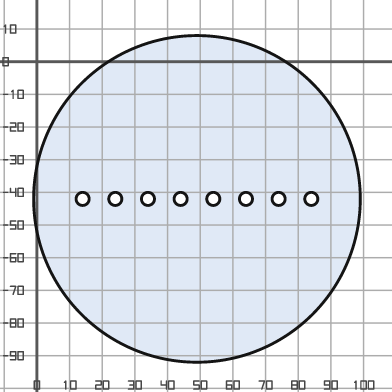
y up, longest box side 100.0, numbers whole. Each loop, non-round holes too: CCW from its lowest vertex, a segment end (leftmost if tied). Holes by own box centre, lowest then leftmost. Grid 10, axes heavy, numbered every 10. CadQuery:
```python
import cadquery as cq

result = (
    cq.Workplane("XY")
    .moveTo(49.0, -42.0)
    .circle(50.0)
    .moveTo(14.0, -42.0)
    .circle(2.0)
    .moveTo(24.0, -42.0)
    .circle(2.0)
    .moveTo(34.0, -42.0)
    .circle(2.0)
    .moveTo(44.0, -42.0)
    .circle(2.0)
    .moveTo(54.0, -42.0)
    .circle(2.0)
    .moveTo(64.0, -42.0)
    .circle(2.0)
    .moveTo(74.0, -42.0)
    .circle(2.0)
    .moveTo(84.0, -42.0)
    .circle(2.0)
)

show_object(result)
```